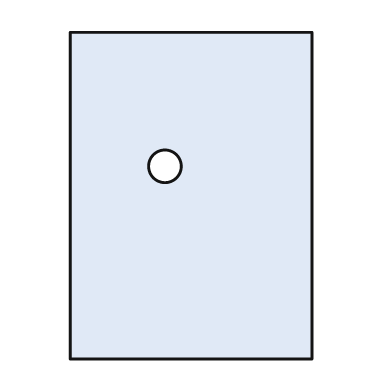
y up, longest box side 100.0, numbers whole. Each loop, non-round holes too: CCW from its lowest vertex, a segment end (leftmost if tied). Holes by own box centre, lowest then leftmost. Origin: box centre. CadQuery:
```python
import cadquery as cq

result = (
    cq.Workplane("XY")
    .moveTo(-37.0, -50.0)
    .lineTo(37.0, -50.0)
    .lineTo(37.0, 50.0)
    .lineTo(-37.0, 50.0)
    .close()
    .moveTo(-8.0, 9.0)
    .circle(5.0)
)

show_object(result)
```